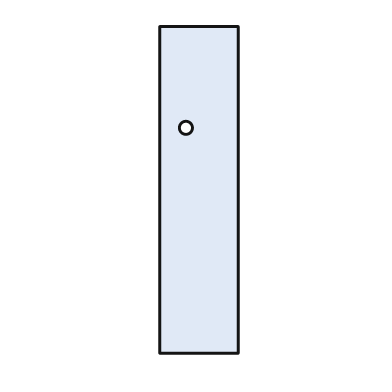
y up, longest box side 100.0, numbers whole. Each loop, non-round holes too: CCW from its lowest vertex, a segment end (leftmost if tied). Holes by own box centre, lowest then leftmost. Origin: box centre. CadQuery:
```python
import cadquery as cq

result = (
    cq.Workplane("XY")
    .moveTo(-12.0, -50.0)
    .lineTo(12.0, -50.0)
    .lineTo(12.0, 50.0)
    .lineTo(-12.0, 50.0)
    .close()
    .moveTo(-4.0, 19.0)
    .circle(2.0)
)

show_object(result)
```